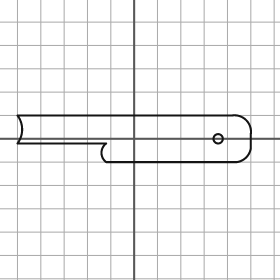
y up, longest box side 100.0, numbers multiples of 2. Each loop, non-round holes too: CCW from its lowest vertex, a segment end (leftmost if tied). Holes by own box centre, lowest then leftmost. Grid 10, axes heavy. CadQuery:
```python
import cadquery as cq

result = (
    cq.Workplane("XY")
    .moveTo(-12.0, -10.0)
    .lineTo(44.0, -10.0)
    .threePointArc((48.0, -8.0), (50.0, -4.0))
    .lineTo(50.0, 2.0)
    .threePointArc((48.0, 8.0), (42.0, 10.0))
    .lineTo(-50.0, 10.0)
    .threePointArc((-48.0, 4.0), (-50.0, -2.0))
    .lineTo(-12.0, -2.0)
    .threePointArc((-14.0, -6.0), (-12.0, -10.0))
    .close()
    .moveTo(36.0, 0.0)
    .circle(2.0)
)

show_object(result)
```